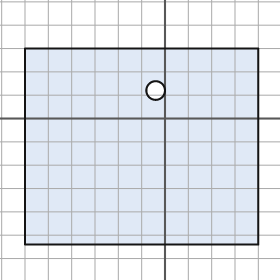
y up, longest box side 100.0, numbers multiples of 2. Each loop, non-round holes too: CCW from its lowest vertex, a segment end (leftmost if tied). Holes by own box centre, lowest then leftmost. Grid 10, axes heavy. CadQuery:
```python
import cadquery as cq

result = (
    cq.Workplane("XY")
    .moveTo(-60.0, -54.0)
    .lineTo(40.0, -54.0)
    .lineTo(40.0, 30.0)
    .lineTo(-60.0, 30.0)
    .close()
    .moveTo(-4.0, 12.0)
    .circle(4.0)
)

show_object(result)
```